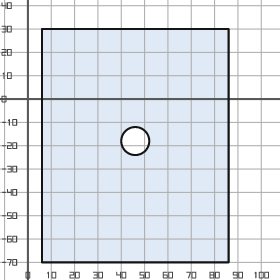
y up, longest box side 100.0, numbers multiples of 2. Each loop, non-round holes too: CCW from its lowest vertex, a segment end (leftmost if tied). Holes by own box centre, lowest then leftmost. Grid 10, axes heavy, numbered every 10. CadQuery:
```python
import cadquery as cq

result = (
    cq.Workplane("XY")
    .moveTo(6.0, -70.0)
    .lineTo(86.0, -70.0)
    .lineTo(86.0, 30.0)
    .lineTo(6.0, 30.0)
    .close()
    .moveTo(46.0, -18.0)
    .circle(6.0)
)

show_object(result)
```